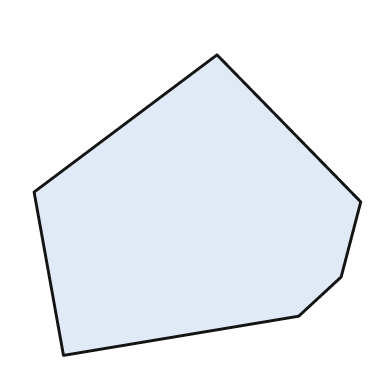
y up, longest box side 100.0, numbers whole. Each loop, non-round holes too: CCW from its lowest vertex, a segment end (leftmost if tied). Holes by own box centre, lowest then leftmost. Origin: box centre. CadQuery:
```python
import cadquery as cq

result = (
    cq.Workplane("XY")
    .moveTo(-41.0, -46.0)
    .lineTo(31.0, -34.0)
    .lineTo(44.0, -22.0)
    .lineTo(50.0, 1.0)
    .lineTo(6.0, 46.0)
    .lineTo(-50.0, 4.0)
    .close()
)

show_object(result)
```